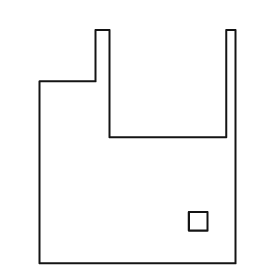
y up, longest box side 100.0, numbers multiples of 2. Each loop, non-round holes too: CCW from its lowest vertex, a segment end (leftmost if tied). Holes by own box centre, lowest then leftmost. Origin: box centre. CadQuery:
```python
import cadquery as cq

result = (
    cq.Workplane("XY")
    .moveTo(-42.0, -50.0)
    .lineTo(42.0, -50.0)
    .lineTo(42.0, 50.0)
    .lineTo(38.0, 50.0)
    .lineTo(38.0, 4.0)
    .lineTo(-12.0, 4.0)
    .lineTo(-12.0, 50.0)
    .lineTo(-18.0, 50.0)
    .lineTo(-18.0, 28.0)
    .lineTo(-42.0, 28.0)
    .close()
    .moveTo(22.0, -36.0)
    .lineTo(30.0, -36.0)
    .lineTo(30.0, -28.0)
    .lineTo(22.0, -28.0)
    .close()
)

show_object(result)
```